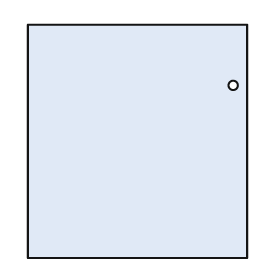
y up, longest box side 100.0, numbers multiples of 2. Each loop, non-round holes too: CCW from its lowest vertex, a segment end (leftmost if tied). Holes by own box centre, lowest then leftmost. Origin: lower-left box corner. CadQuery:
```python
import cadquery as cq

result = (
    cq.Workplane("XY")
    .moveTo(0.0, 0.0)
    .lineTo(94.0, 0.0)
    .lineTo(94.0, 100.0)
    .lineTo(0.0, 100.0)
    .close()
    .moveTo(88.0, 74.0)
    .circle(2.0)
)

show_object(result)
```